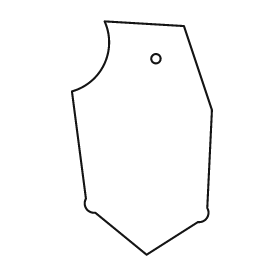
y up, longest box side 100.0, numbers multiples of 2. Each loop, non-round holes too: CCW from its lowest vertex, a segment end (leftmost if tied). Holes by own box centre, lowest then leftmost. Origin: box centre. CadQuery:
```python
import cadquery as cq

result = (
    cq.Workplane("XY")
    .moveTo(2.0, -50.0)
    .lineTo(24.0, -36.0)
    .threePointArc((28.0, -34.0), (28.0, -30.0))
    .lineTo(30.0, 12.0)
    .lineTo(18.0, 48.0)
    .lineTo(-16.0, 50.0)
    .threePointArc((-16.0, 32.0), (-30.0, 20.0))
    .lineTo(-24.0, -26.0)
    .threePointArc((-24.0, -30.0), (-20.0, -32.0))
    .close()
    .moveTo(6.0, 34.0)
    .circle(2.0)
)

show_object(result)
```